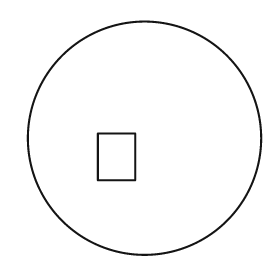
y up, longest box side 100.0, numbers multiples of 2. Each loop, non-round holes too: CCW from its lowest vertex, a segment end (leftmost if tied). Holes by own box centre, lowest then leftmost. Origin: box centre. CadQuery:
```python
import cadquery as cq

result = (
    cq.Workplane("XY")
    .moveTo(0.0, 0.0)
    .circle(50.0)
    .moveTo(-20.0, -18.0)
    .lineTo(-4.0, -18.0)
    .lineTo(-4.0, 2.0)
    .lineTo(-20.0, 2.0)
    .close()
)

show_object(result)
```